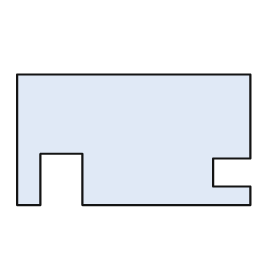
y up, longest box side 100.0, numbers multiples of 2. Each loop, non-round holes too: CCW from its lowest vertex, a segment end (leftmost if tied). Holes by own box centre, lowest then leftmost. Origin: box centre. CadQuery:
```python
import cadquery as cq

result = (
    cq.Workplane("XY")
    .moveTo(-50.0, -28.0)
    .lineTo(-40.0, -28.0)
    .lineTo(-40.0, -6.0)
    .lineTo(-22.0, -6.0)
    .lineTo(-22.0, -28.0)
    .lineTo(50.0, -28.0)
    .lineTo(50.0, -20.0)
    .lineTo(34.0, -20.0)
    .lineTo(34.0, -8.0)
    .lineTo(50.0, -8.0)
    .lineTo(50.0, 28.0)
    .lineTo(-50.0, 28.0)
    .close()
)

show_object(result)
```